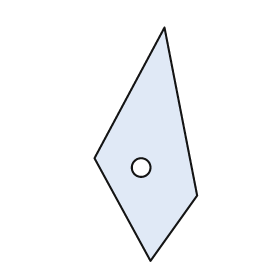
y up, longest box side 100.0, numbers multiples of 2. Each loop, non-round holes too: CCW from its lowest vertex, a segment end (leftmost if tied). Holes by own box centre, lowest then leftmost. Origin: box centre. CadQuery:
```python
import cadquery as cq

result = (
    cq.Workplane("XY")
    .moveTo(2.0, -50.0)
    .lineTo(22.0, -22.0)
    .lineTo(8.0, 50.0)
    .lineTo(-22.0, -6.0)
    .close()
    .moveTo(-2.0, -10.0)
    .circle(4.0)
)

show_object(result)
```